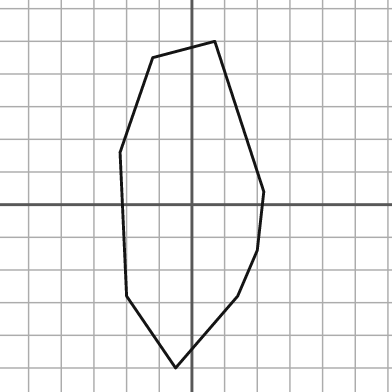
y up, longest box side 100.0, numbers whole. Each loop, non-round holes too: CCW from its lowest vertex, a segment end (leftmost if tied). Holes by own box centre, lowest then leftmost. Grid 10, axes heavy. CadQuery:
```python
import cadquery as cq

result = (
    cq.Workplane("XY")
    .moveTo(-5.0, -50.0)
    .lineTo(14.0, -28.0)
    .lineTo(20.0, -14.0)
    .lineTo(22.0, 4.0)
    .lineTo(7.0, 50.0)
    .lineTo(-12.0, 45.0)
    .lineTo(-22.0, 16.0)
    .lineTo(-20.0, -28.0)
    .close()
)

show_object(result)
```